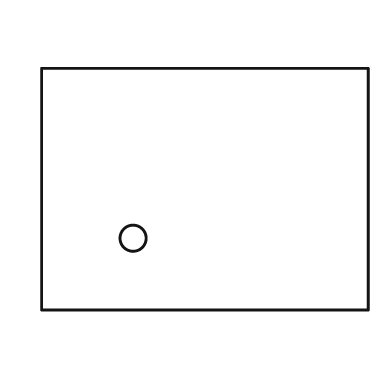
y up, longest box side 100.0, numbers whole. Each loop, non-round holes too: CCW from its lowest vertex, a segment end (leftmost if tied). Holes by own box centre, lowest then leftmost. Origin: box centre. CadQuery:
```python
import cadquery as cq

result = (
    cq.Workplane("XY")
    .moveTo(-50.0, -37.0)
    .lineTo(50.0, -37.0)
    .lineTo(50.0, 37.0)
    .lineTo(-50.0, 37.0)
    .close()
    .moveTo(-22.0, -15.0)
    .circle(4.0)
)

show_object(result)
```